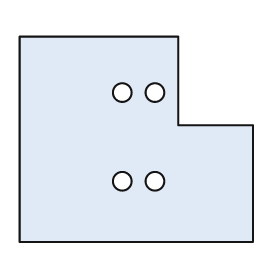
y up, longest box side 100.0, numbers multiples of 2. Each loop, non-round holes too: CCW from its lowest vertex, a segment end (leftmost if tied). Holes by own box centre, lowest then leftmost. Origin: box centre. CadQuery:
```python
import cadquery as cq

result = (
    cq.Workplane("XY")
    .moveTo(-50.0, -44.0)
    .lineTo(50.0, -44.0)
    .lineTo(50.0, 6.0)
    .lineTo(18.0, 6.0)
    .lineTo(18.0, 44.0)
    .lineTo(-50.0, 44.0)
    .close()
    .moveTo(-6.0, -18.0)
    .circle(4.0)
    .moveTo(8.0, -18.0)
    .circle(4.0)
    .moveTo(-6.0, 20.0)
    .circle(4.0)
    .moveTo(8.0, 20.0)
    .circle(4.0)
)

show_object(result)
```